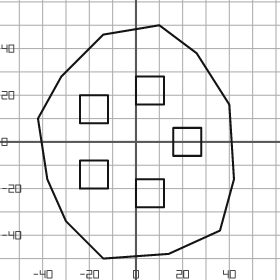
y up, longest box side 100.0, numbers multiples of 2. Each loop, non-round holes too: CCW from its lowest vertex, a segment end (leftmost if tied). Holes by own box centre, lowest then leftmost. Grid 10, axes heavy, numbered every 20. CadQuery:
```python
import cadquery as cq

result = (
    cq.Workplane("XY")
    .moveTo(-14.0, -50.0)
    .lineTo(14.0, -48.0)
    .lineTo(36.0, -38.0)
    .lineTo(42.0, -16.0)
    .lineTo(40.0, 16.0)
    .lineTo(26.0, 38.0)
    .lineTo(10.0, 50.0)
    .lineTo(-14.0, 46.0)
    .lineTo(-32.0, 28.0)
    .lineTo(-42.0, 10.0)
    .lineTo(-38.0, -16.0)
    .lineTo(-30.0, -34.0)
    .close()
    .moveTo(0.0, -28.0)
    .lineTo(12.0, -28.0)
    .lineTo(12.0, -16.0)
    .lineTo(0.0, -16.0)
    .close()
    .moveTo(-24.0, -20.0)
    .lineTo(-12.0, -20.0)
    .lineTo(-12.0, -8.0)
    .lineTo(-24.0, -8.0)
    .close()
    .moveTo(16.0, -6.0)
    .lineTo(28.0, -6.0)
    .lineTo(28.0, 6.0)
    .lineTo(16.0, 6.0)
    .close()
    .moveTo(-24.0, 8.0)
    .lineTo(-12.0, 8.0)
    .lineTo(-12.0, 20.0)
    .lineTo(-24.0, 20.0)
    .close()
    .moveTo(0.0, 16.0)
    .lineTo(12.0, 16.0)
    .lineTo(12.0, 28.0)
    .lineTo(0.0, 28.0)
    .close()
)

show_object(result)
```